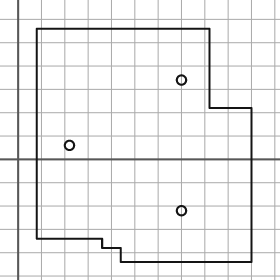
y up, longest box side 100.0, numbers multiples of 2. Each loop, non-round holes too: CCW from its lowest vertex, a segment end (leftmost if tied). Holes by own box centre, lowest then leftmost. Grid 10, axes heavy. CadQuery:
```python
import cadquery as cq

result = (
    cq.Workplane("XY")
    .moveTo(44.0, -44.0)
    .lineTo(100.0, -44.0)
    .lineTo(100.0, 22.0)
    .lineTo(82.0, 22.0)
    .lineTo(82.0, 56.0)
    .lineTo(8.0, 56.0)
    .lineTo(8.0, -34.0)
    .lineTo(36.0, -34.0)
    .lineTo(36.0, -38.0)
    .lineTo(44.0, -38.0)
    .close()
    .moveTo(70.0, -22.0)
    .circle(2.0)
    .moveTo(22.0, 6.0)
    .circle(2.0)
    .moveTo(70.0, 34.0)
    .circle(2.0)
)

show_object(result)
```